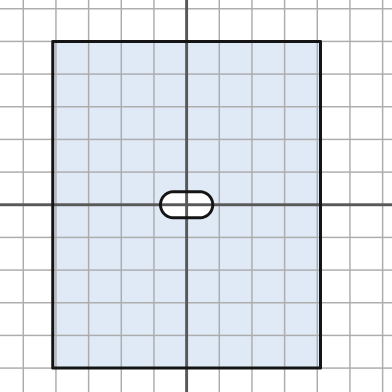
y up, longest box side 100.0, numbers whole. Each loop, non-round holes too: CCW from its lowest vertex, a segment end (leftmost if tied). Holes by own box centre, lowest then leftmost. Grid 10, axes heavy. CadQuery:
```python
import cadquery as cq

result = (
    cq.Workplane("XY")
    .moveTo(-41.0, -50.0)
    .lineTo(41.0, -50.0)
    .lineTo(41.0, 50.0)
    .lineTo(-41.0, 50.0)
    .close()
    .moveTo(-4.0, -4.0)
    .lineTo(4.0, -4.0)
    .threePointArc((8.0, 0.0), (4.0, 4.0))
    .lineTo(-4.0, 4.0)
    .threePointArc((-8.0, 0.0), (-4.0, -4.0))
    .close()
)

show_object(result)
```